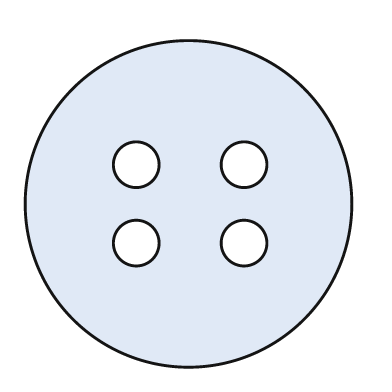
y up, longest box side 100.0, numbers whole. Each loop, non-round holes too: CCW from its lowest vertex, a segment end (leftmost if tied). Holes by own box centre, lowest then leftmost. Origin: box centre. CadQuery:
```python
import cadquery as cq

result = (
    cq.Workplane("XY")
    .moveTo(0.0, 0.0)
    .circle(50.0)
    .moveTo(-16.0, -12.0)
    .circle(7.0)
    .moveTo(17.0, -12.0)
    .circle(7.0)
    .moveTo(-16.0, 12.0)
    .circle(7.0)
    .moveTo(17.0, 12.0)
    .circle(7.0)
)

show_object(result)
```